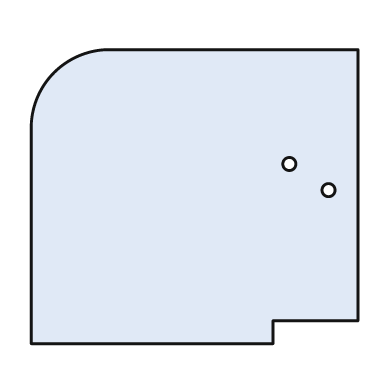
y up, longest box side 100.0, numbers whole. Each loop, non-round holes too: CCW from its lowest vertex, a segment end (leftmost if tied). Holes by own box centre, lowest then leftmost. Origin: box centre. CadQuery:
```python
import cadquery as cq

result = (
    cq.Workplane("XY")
    .moveTo(-50.0, -45.0)
    .lineTo(24.0, -45.0)
    .lineTo(24.0, -38.0)
    .lineTo(50.0, -38.0)
    .lineTo(50.0, 45.0)
    .lineTo(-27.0, 45.0)
    .threePointArc((-43.0, 38.0), (-50.0, 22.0))
    .close()
    .moveTo(41.0, 2.0)
    .circle(2.0)
    .moveTo(29.0, 10.0)
    .circle(2.0)
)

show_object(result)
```